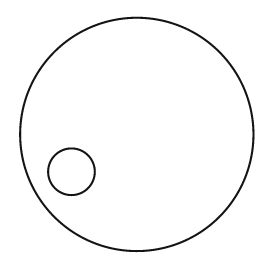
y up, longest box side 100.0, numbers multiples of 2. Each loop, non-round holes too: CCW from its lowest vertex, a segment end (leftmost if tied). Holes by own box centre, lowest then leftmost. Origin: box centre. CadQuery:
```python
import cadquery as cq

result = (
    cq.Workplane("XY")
    .moveTo(0.0, 0.0)
    .circle(50.0)
    .moveTo(-28.0, -16.0)
    .circle(10.0)
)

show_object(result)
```